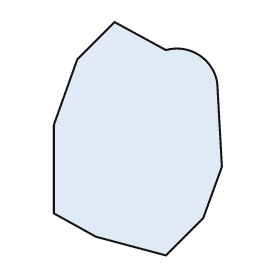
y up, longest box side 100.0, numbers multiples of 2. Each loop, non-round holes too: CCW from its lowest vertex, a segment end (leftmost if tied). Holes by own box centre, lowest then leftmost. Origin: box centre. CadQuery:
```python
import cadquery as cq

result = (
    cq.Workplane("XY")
    .moveTo(12.0, -50.0)
    .lineTo(28.0, -34.0)
    .lineTo(36.0, -12.0)
    .lineTo(34.0, 24.0)
    .threePointArc((26.0, 36.0), (12.0, 38.0))
    .lineTo(-10.0, 50.0)
    .lineTo(-26.0, 34.0)
    .lineTo(-36.0, 6.0)
    .lineTo(-36.0, -32.0)
    .lineTo(-18.0, -42.0)
    .close()
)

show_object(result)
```